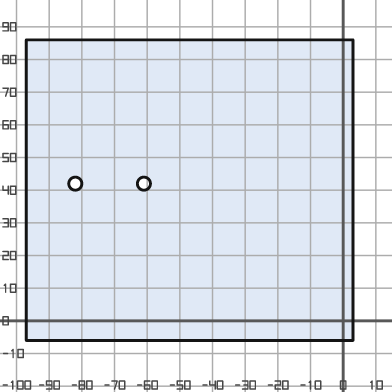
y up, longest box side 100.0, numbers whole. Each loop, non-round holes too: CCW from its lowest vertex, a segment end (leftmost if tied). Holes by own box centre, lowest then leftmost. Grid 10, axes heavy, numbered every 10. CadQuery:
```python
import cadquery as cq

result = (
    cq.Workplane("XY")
    .moveTo(-97.0, -6.0)
    .lineTo(3.0, -6.0)
    .lineTo(3.0, 86.0)
    .lineTo(-97.0, 86.0)
    .close()
    .moveTo(-82.0, 42.0)
    .circle(2.0)
    .moveTo(-61.0, 42.0)
    .circle(2.0)
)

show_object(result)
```